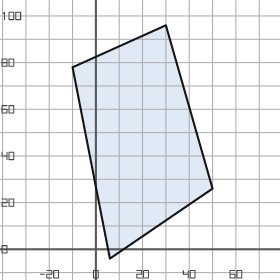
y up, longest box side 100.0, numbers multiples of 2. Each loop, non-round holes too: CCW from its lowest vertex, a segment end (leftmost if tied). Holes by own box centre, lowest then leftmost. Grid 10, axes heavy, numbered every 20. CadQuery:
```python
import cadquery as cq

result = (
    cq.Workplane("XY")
    .moveTo(6.0, -4.0)
    .lineTo(50.0, 26.0)
    .lineTo(30.0, 96.0)
    .lineTo(-10.0, 78.0)
    .close()
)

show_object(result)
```